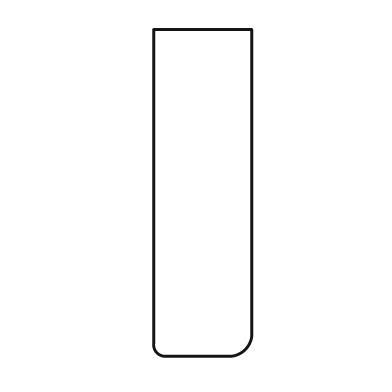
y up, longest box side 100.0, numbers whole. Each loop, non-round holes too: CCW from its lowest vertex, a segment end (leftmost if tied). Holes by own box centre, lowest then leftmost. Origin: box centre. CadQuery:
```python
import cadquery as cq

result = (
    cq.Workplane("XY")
    .moveTo(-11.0, -50.0)
    .lineTo(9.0, -50.0)
    .threePointArc((13.0, -48.0), (15.0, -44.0))
    .lineTo(15.0, 50.0)
    .lineTo(-15.0, 50.0)
    .lineTo(-15.0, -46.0)
    .threePointArc((-14.0, -49.0), (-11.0, -50.0))
    .close()
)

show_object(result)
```